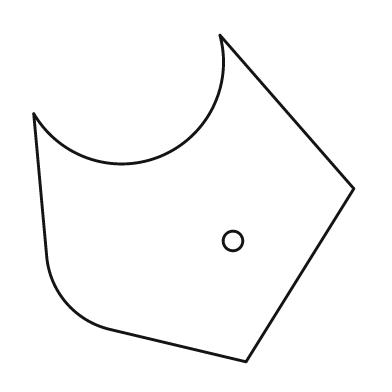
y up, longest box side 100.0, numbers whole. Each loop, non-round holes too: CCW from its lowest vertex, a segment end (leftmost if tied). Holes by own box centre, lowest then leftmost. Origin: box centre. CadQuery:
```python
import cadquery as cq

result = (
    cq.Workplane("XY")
    .moveTo(16.0, -50.0)
    .lineTo(49.0, 3.0)
    .lineTo(8.0, 50.0)
    .threePointArc((-10.0, 13.0), (-49.0, 26.0))
    .lineTo(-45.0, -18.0)
    .threePointArc((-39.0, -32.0), (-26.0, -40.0))
    .close()
    .moveTo(12.0, -13.0)
    .circle(3.0)
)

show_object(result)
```